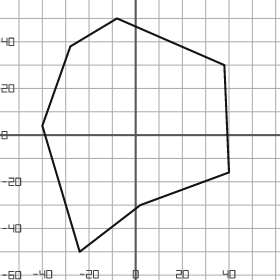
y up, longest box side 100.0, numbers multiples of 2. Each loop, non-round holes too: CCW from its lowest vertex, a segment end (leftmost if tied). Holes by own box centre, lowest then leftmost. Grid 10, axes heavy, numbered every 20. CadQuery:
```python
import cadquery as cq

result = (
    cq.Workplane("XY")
    .moveTo(-24.0, -50.0)
    .lineTo(2.0, -30.0)
    .lineTo(40.0, -16.0)
    .lineTo(38.0, 30.0)
    .lineTo(-8.0, 50.0)
    .lineTo(-28.0, 38.0)
    .lineTo(-40.0, 4.0)
    .close()
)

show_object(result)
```